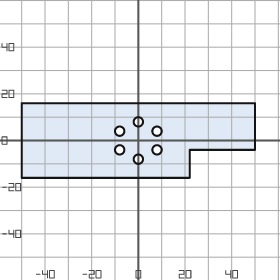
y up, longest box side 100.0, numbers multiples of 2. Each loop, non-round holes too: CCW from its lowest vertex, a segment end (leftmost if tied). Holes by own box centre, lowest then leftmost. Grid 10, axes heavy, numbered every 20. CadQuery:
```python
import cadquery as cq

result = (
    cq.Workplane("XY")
    .moveTo(-50.0, -16.0)
    .lineTo(22.0, -16.0)
    .lineTo(22.0, -4.0)
    .lineTo(50.0, -4.0)
    .lineTo(50.0, 16.0)
    .lineTo(-50.0, 16.0)
    .close()
    .moveTo(0.0, -8.0)
    .circle(2.0)
    .moveTo(-8.0, -4.0)
    .circle(2.0)
    .moveTo(8.0, -4.0)
    .circle(2.0)
    .moveTo(-8.0, 4.0)
    .circle(2.0)
    .moveTo(8.0, 4.0)
    .circle(2.0)
    .moveTo(0.0, 8.0)
    .circle(2.0)
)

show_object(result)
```